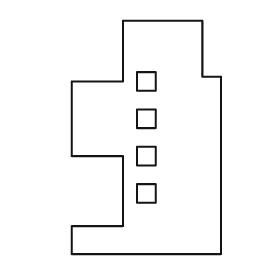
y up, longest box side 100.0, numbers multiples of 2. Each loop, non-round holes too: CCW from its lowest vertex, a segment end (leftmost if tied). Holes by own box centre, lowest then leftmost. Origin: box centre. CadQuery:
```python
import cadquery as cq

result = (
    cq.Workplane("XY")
    .moveTo(-32.0, -50.0)
    .lineTo(32.0, -50.0)
    .lineTo(32.0, 26.0)
    .lineTo(24.0, 26.0)
    .lineTo(24.0, 50.0)
    .lineTo(-10.0, 50.0)
    .lineTo(-10.0, 24.0)
    .lineTo(-32.0, 24.0)
    .lineTo(-32.0, -8.0)
    .lineTo(-10.0, -8.0)
    .lineTo(-10.0, -38.0)
    .lineTo(-32.0, -38.0)
    .close()
    .moveTo(-4.0, -28.0)
    .lineTo(4.0, -28.0)
    .lineTo(4.0, -20.0)
    .lineTo(-4.0, -20.0)
    .close()
    .moveTo(-4.0, -12.0)
    .lineTo(4.0, -12.0)
    .lineTo(4.0, -4.0)
    .lineTo(-4.0, -4.0)
    .close()
    .moveTo(-4.0, 4.0)
    .lineTo(4.0, 4.0)
    .lineTo(4.0, 12.0)
    .lineTo(-4.0, 12.0)
    .close()
    .moveTo(-4.0, 20.0)
    .lineTo(4.0, 20.0)
    .lineTo(4.0, 28.0)
    .lineTo(-4.0, 28.0)
    .close()
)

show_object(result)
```